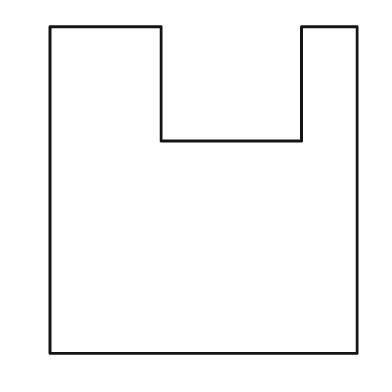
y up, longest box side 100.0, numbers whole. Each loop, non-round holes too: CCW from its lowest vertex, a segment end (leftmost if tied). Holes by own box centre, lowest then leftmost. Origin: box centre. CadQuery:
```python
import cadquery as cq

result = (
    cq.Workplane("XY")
    .moveTo(-47.0, -50.0)
    .lineTo(47.0, -50.0)
    .lineTo(47.0, 50.0)
    .lineTo(30.0, 50.0)
    .lineTo(30.0, 15.0)
    .lineTo(-13.0, 15.0)
    .lineTo(-13.0, 50.0)
    .lineTo(-47.0, 50.0)
    .close()
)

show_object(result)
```